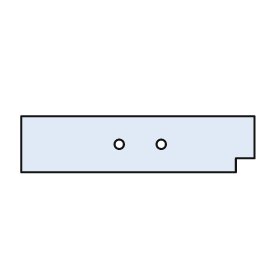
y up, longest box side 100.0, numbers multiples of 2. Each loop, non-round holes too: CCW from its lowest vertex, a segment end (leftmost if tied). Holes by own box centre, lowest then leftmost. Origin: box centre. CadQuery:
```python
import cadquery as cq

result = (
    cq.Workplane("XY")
    .moveTo(-50.0, -12.0)
    .lineTo(42.0, -12.0)
    .lineTo(42.0, -6.0)
    .lineTo(50.0, -6.0)
    .lineTo(50.0, 12.0)
    .lineTo(-50.0, 12.0)
    .close()
    .moveTo(-8.0, 0.0)
    .circle(2.0)
    .moveTo(10.0, 0.0)
    .circle(2.0)
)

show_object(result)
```